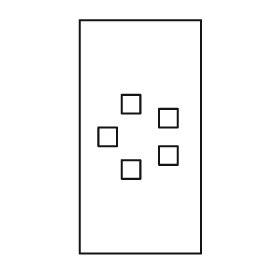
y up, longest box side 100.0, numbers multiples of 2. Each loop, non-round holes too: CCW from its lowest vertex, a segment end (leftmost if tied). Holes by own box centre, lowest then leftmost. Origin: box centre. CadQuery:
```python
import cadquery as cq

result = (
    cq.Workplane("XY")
    .moveTo(-26.0, -50.0)
    .lineTo(26.0, -50.0)
    .lineTo(26.0, 50.0)
    .lineTo(-26.0, 50.0)
    .close()
    .moveTo(-8.0, -18.0)
    .lineTo(0.0, -18.0)
    .lineTo(0.0, -10.0)
    .lineTo(-8.0, -10.0)
    .close()
    .moveTo(8.0, -12.0)
    .lineTo(16.0, -12.0)
    .lineTo(16.0, -4.0)
    .lineTo(8.0, -4.0)
    .close()
    .moveTo(-18.0, -4.0)
    .lineTo(-10.0, -4.0)
    .lineTo(-10.0, 4.0)
    .lineTo(-18.0, 4.0)
    .close()
    .moveTo(8.0, 4.0)
    .lineTo(16.0, 4.0)
    .lineTo(16.0, 12.0)
    .lineTo(8.0, 12.0)
    .close()
    .moveTo(-8.0, 10.0)
    .lineTo(0.0, 10.0)
    .lineTo(0.0, 18.0)
    .lineTo(-8.0, 18.0)
    .close()
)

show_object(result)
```